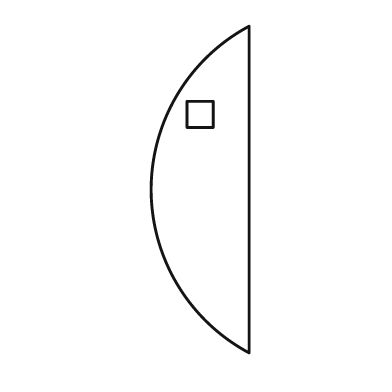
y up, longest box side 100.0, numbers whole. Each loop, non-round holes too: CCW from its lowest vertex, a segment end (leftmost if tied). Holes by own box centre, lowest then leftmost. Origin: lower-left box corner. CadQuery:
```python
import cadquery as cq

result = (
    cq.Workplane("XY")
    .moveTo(30.0, 0.0)
    .lineTo(30.0, 100.0)
    .threePointArc((0.0, 50.0), (30.0, 0.0))
    .close()
    .moveTo(11.0, 69.0)
    .lineTo(19.0, 69.0)
    .lineTo(19.0, 77.0)
    .lineTo(11.0, 77.0)
    .close()
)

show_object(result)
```